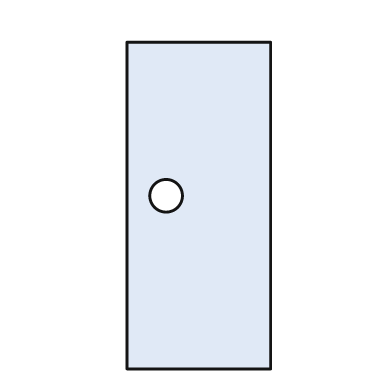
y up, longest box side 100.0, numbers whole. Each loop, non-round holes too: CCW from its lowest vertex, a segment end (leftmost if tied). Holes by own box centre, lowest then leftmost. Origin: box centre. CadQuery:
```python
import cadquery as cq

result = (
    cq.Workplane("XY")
    .moveTo(-22.0, -50.0)
    .lineTo(22.0, -50.0)
    .lineTo(22.0, 50.0)
    .lineTo(-22.0, 50.0)
    .close()
    .moveTo(-10.0, 3.0)
    .circle(5.0)
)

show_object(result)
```